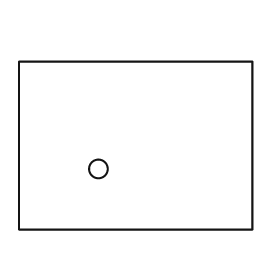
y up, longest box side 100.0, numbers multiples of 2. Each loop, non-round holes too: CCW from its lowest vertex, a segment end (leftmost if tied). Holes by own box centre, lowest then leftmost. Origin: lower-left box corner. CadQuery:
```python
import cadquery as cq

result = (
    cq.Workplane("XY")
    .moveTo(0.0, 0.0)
    .lineTo(100.0, 0.0)
    .lineTo(100.0, 72.0)
    .lineTo(0.0, 72.0)
    .close()
    .moveTo(34.0, 26.0)
    .circle(4.0)
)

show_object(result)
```